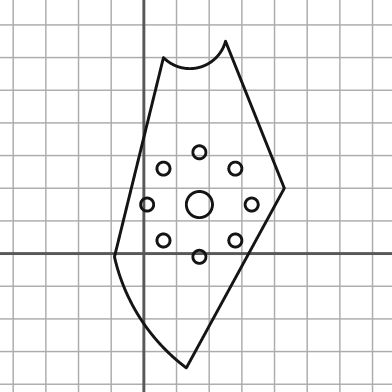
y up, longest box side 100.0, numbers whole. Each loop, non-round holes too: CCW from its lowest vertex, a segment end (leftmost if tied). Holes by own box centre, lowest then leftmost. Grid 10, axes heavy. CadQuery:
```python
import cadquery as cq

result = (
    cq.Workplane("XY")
    .moveTo(13.0, -35.0)
    .lineTo(43.0, 20.0)
    .lineTo(25.0, 65.0)
    .threePointArc((17.0, 57.0), (6.0, 60.0))
    .lineTo(-9.0, -1.0)
    .threePointArc((-1.0, -20.0), (13.0, -35.0))
    .close()
    .moveTo(17.0, -1.0)
    .circle(2.0)
    .moveTo(6.0, 4.0)
    .circle(2.0)
    .moveTo(28.0, 4.0)
    .circle(2.0)
    .moveTo(1.0, 15.0)
    .circle(2.0)
    .moveTo(17.0, 15.0)
    .circle(4.0)
    .moveTo(33.0, 15.0)
    .circle(2.0)
    .moveTo(6.0, 26.0)
    .circle(2.0)
    .moveTo(28.0, 26.0)
    .circle(2.0)
    .moveTo(17.0, 31.0)
    .circle(2.0)
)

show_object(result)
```